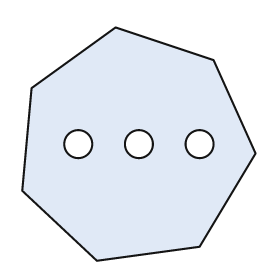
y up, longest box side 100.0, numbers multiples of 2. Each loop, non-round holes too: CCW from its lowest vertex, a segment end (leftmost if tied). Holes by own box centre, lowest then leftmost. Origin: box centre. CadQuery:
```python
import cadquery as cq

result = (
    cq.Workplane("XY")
    .moveTo(-18.0, -50.0)
    .lineTo(26.0, -44.0)
    .lineTo(50.0, -4.0)
    .lineTo(32.0, 36.0)
    .lineTo(-10.0, 50.0)
    .lineTo(-46.0, 24.0)
    .lineTo(-50.0, -20.0)
    .close()
    .moveTo(-26.0, 0.0)
    .circle(6.0)
    .moveTo(0.0, 0.0)
    .circle(6.0)
    .moveTo(26.0, 0.0)
    .circle(6.0)
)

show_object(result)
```